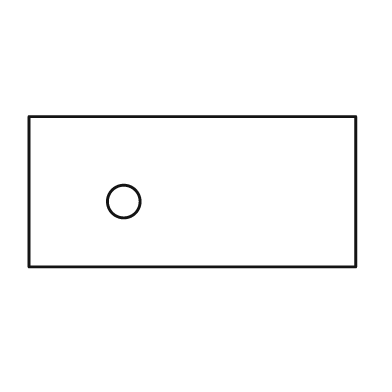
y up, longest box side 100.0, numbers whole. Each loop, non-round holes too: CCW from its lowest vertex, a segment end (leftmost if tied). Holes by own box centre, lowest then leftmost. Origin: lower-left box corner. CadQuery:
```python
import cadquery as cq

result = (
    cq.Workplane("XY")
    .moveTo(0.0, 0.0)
    .lineTo(100.0, 0.0)
    .lineTo(100.0, 46.0)
    .lineTo(0.0, 46.0)
    .close()
    .moveTo(29.0, 20.0)
    .circle(5.0)
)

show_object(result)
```